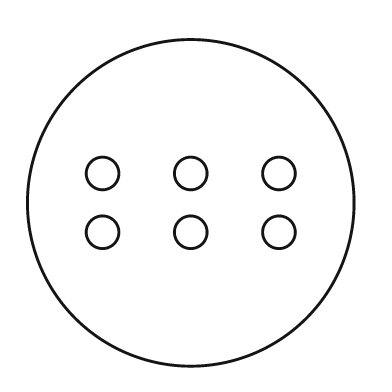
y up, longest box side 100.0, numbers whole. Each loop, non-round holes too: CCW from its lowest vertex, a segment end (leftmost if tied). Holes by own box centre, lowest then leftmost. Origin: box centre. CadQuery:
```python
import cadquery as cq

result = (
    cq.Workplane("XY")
    .moveTo(0.0, 0.0)
    .circle(50.0)
    .moveTo(-27.0, -9.0)
    .circle(5.0)
    .moveTo(0.0, -9.0)
    .circle(5.0)
    .moveTo(27.0, -9.0)
    .circle(5.0)
    .moveTo(-27.0, 9.0)
    .circle(5.0)
    .moveTo(0.0, 9.0)
    .circle(5.0)
    .moveTo(27.0, 9.0)
    .circle(5.0)
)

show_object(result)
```